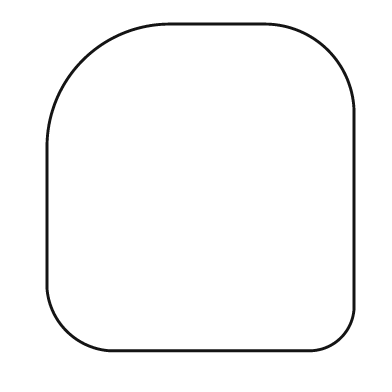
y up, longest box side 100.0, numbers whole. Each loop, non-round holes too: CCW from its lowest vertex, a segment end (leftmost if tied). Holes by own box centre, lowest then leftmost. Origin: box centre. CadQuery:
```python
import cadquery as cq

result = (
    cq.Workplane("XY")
    .moveTo(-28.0, -50.0)
    .lineTo(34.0, -50.0)
    .threePointArc((43.0, -46.0), (47.0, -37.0))
    .lineTo(47.0, 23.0)
    .threePointArc((39.0, 42.0), (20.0, 50.0))
    .lineTo(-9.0, 50.0)
    .threePointArc((-36.0, 39.0), (-47.0, 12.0))
    .lineTo(-47.0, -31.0)
    .threePointArc((-41.0, -44.0), (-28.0, -50.0))
    .close()
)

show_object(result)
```